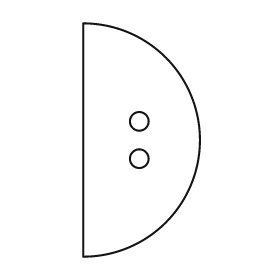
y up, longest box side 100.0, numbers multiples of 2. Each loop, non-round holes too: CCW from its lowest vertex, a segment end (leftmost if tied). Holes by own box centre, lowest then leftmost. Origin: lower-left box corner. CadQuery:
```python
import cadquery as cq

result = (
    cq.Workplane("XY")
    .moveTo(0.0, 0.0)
    .threePointArc((50.0, 50.0), (0.0, 100.0))
    .close()
    .moveTo(24.0, 42.0)
    .circle(4.0)
    .moveTo(24.0, 58.0)
    .circle(4.0)
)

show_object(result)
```